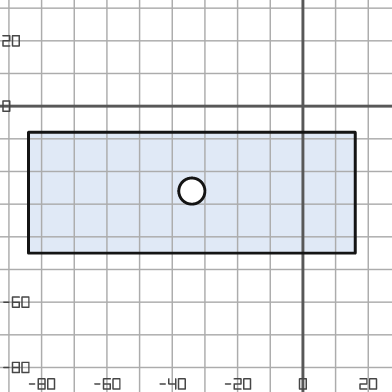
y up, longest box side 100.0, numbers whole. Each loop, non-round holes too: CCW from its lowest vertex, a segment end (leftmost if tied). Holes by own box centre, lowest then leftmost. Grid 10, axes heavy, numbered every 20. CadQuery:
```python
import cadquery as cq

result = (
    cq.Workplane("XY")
    .moveTo(-84.0, -45.0)
    .lineTo(16.0, -45.0)
    .lineTo(16.0, -8.0)
    .lineTo(-84.0, -8.0)
    .close()
    .moveTo(-34.0, -26.0)
    .circle(4.0)
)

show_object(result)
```